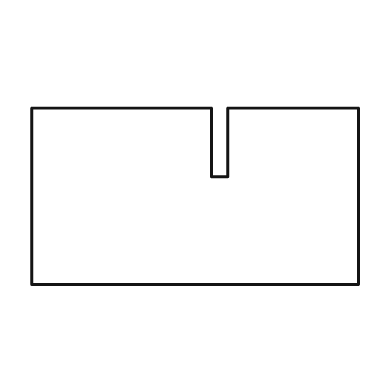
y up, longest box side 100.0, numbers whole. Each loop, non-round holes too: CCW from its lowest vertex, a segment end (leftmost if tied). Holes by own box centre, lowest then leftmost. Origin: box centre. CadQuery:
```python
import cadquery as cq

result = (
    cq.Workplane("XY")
    .moveTo(-50.0, -27.0)
    .lineTo(50.0, -27.0)
    .lineTo(50.0, 27.0)
    .lineTo(10.0, 27.0)
    .lineTo(10.0, 6.0)
    .lineTo(5.0, 6.0)
    .lineTo(5.0, 27.0)
    .lineTo(-50.0, 27.0)
    .close()
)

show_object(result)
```